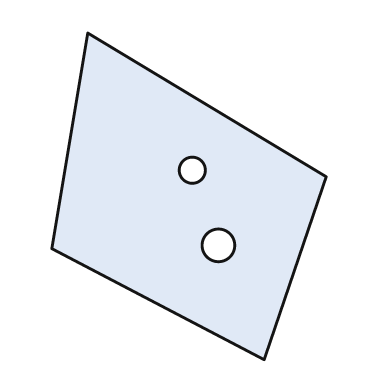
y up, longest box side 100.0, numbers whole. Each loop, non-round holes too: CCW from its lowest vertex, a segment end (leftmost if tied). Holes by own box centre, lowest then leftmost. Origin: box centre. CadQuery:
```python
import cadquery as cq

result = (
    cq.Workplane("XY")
    .moveTo(23.0, -50.0)
    .lineTo(42.0, 6.0)
    .lineTo(-31.0, 50.0)
    .lineTo(-42.0, -16.0)
    .close()
    .moveTo(9.0, -15.0)
    .circle(5.0)
    .moveTo(1.0, 8.0)
    .circle(4.0)
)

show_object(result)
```